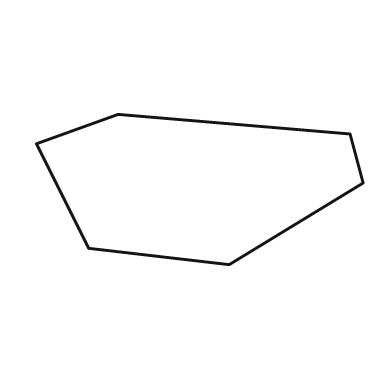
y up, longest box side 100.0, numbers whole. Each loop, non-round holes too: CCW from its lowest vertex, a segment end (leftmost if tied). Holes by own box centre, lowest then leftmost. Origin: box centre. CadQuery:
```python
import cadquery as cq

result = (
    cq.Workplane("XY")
    .moveTo(9.0, -23.0)
    .lineTo(50.0, 2.0)
    .lineTo(46.0, 17.0)
    .lineTo(-25.0, 23.0)
    .lineTo(-50.0, 14.0)
    .lineTo(-34.0, -18.0)
    .close()
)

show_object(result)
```